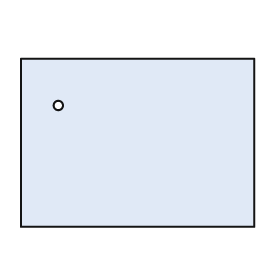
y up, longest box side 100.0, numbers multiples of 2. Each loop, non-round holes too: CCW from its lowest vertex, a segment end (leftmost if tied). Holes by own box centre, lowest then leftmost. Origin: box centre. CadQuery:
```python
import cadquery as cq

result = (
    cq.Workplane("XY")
    .moveTo(-50.0, -36.0)
    .lineTo(50.0, -36.0)
    .lineTo(50.0, 36.0)
    .lineTo(-50.0, 36.0)
    .close()
    .moveTo(-34.0, 16.0)
    .circle(2.0)
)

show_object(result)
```